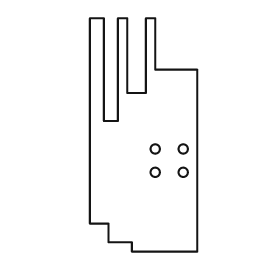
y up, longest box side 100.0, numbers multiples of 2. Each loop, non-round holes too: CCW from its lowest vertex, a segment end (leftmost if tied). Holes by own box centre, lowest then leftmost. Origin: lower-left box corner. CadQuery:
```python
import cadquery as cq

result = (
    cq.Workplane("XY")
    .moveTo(18.0, 0.0)
    .lineTo(46.0, 0.0)
    .lineTo(46.0, 78.0)
    .lineTo(28.0, 78.0)
    .lineTo(28.0, 100.0)
    .lineTo(24.0, 100.0)
    .lineTo(24.0, 68.0)
    .lineTo(16.0, 68.0)
    .lineTo(16.0, 100.0)
    .lineTo(12.0, 100.0)
    .lineTo(12.0, 56.0)
    .lineTo(6.0, 56.0)
    .lineTo(6.0, 100.0)
    .lineTo(0.0, 100.0)
    .lineTo(0.0, 12.0)
    .lineTo(8.0, 12.0)
    .lineTo(8.0, 4.0)
    .lineTo(18.0, 4.0)
    .close()
    .moveTo(28.0, 34.0)
    .circle(2.0)
    .moveTo(40.0, 34.0)
    .circle(2.0)
    .moveTo(28.0, 44.0)
    .circle(2.0)
    .moveTo(40.0, 44.0)
    .circle(2.0)
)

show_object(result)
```